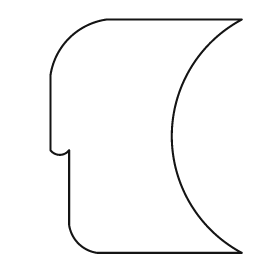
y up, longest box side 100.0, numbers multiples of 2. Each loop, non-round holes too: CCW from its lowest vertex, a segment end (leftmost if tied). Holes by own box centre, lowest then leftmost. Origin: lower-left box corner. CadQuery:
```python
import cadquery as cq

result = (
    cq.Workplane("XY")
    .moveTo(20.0, 0.0)
    .lineTo(82.0, 0.0)
    .threePointArc((52.0, 50.0), (82.0, 100.0))
    .lineTo(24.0, 100.0)
    .threePointArc((8.0, 92.0), (0.0, 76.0))
    .lineTo(0.0, 44.0)
    .threePointArc((4.0, 42.0), (8.0, 44.0))
    .lineTo(8.0, 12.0)
    .threePointArc((12.0, 4.0), (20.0, 0.0))
    .close()
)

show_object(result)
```